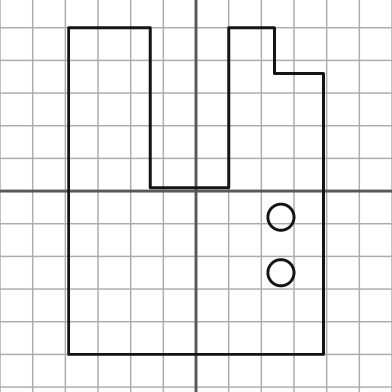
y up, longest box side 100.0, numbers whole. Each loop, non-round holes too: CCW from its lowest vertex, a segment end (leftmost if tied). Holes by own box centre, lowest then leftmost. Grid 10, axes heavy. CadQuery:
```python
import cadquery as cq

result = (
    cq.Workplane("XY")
    .moveTo(-39.0, -50.0)
    .lineTo(39.0, -50.0)
    .lineTo(39.0, 36.0)
    .lineTo(24.0, 36.0)
    .lineTo(24.0, 50.0)
    .lineTo(10.0, 50.0)
    .lineTo(10.0, 1.0)
    .lineTo(-14.0, 1.0)
    .lineTo(-14.0, 50.0)
    .lineTo(-39.0, 50.0)
    .close()
    .moveTo(26.0, -25.0)
    .circle(4.0)
    .moveTo(26.0, -8.0)
    .circle(4.0)
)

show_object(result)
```